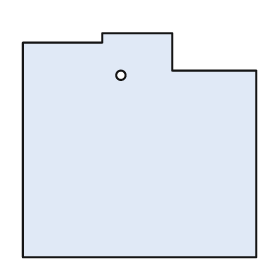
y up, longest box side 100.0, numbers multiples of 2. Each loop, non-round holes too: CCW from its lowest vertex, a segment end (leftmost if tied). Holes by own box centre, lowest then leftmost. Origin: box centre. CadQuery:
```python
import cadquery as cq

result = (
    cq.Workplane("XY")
    .moveTo(-50.0, -48.0)
    .lineTo(50.0, -48.0)
    .lineTo(50.0, 32.0)
    .lineTo(14.0, 32.0)
    .lineTo(14.0, 48.0)
    .lineTo(-16.0, 48.0)
    .lineTo(-16.0, 44.0)
    .lineTo(-50.0, 44.0)
    .close()
    .moveTo(-8.0, 30.0)
    .circle(2.0)
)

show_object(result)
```